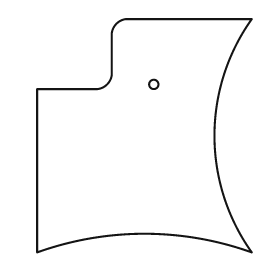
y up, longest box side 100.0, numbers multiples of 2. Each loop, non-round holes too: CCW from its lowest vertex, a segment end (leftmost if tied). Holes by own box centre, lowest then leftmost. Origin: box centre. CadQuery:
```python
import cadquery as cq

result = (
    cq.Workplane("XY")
    .moveTo(-46.0, -50.0)
    .threePointArc((0.0, -42.0), (46.0, -50.0))
    .threePointArc((30.0, 0.0), (46.0, 50.0))
    .lineTo(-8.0, 50.0)
    .threePointArc((-12.0, 48.0), (-14.0, 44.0))
    .lineTo(-14.0, 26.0)
    .threePointArc((-16.0, 22.0), (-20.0, 20.0))
    .lineTo(-46.0, 20.0)
    .close()
    .moveTo(4.0, 22.0)
    .circle(2.0)
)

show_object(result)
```